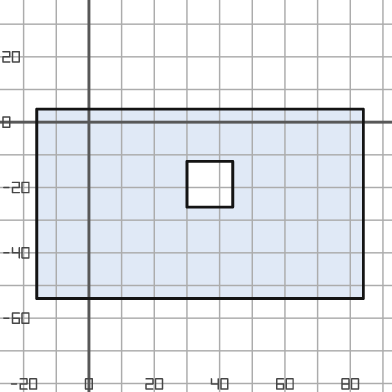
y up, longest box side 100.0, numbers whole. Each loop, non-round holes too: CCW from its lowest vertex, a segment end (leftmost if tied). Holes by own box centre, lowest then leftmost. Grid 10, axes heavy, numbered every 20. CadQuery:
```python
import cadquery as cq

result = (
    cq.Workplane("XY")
    .moveTo(-16.0, -54.0)
    .lineTo(84.0, -54.0)
    .lineTo(84.0, 4.0)
    .lineTo(-16.0, 4.0)
    .close()
    .moveTo(30.0, -26.0)
    .lineTo(44.0, -26.0)
    .lineTo(44.0, -12.0)
    .lineTo(30.0, -12.0)
    .close()
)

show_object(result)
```